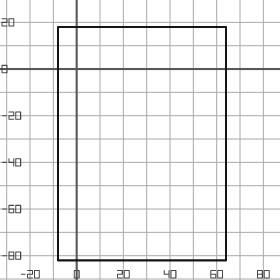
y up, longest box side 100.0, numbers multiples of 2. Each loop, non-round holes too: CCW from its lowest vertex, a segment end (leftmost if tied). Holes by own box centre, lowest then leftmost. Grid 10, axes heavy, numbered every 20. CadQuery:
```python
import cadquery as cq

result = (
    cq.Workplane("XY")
    .moveTo(-8.0, -82.0)
    .lineTo(64.0, -82.0)
    .lineTo(64.0, 18.0)
    .lineTo(-8.0, 18.0)
    .close()
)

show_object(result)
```